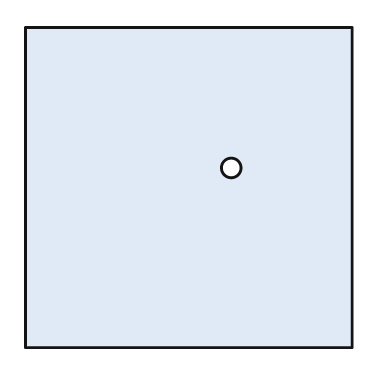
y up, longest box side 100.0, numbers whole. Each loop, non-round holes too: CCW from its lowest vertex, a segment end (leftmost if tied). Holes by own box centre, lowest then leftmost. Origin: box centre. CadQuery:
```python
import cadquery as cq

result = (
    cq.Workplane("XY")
    .moveTo(-50.0, -49.0)
    .lineTo(50.0, -49.0)
    .lineTo(50.0, 49.0)
    .lineTo(-50.0, 49.0)
    .close()
    .moveTo(13.0, 6.0)
    .circle(3.0)
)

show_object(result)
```